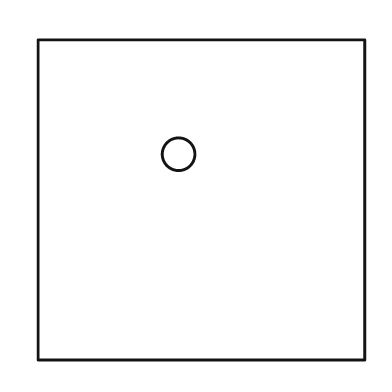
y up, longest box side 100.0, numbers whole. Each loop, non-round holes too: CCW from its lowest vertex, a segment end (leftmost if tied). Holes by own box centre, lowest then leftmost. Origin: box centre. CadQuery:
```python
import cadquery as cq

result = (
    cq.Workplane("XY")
    .moveTo(-50.0, -49.0)
    .lineTo(50.0, -49.0)
    .lineTo(50.0, 49.0)
    .lineTo(-50.0, 49.0)
    .close()
    .moveTo(-7.0, 14.0)
    .circle(5.0)
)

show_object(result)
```